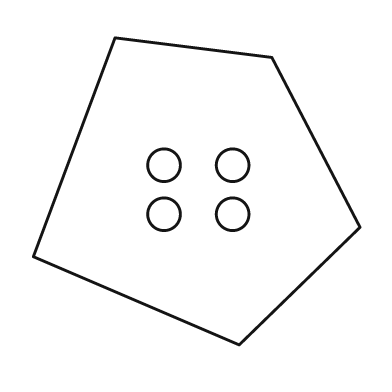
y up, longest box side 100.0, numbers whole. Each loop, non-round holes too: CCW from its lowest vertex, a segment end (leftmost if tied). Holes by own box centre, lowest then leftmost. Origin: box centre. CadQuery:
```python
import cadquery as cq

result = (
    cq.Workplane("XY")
    .moveTo(13.0, -47.0)
    .lineTo(50.0, -11.0)
    .lineTo(23.0, 41.0)
    .lineTo(-25.0, 47.0)
    .lineTo(-50.0, -20.0)
    .close()
    .moveTo(-10.0, -7.0)
    .circle(5.0)
    .moveTo(11.0, -7.0)
    .circle(5.0)
    .moveTo(-10.0, 8.0)
    .circle(5.0)
    .moveTo(11.0, 8.0)
    .circle(5.0)
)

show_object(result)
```